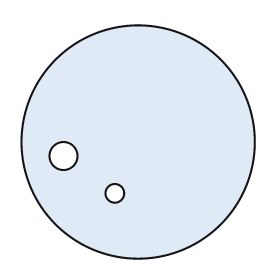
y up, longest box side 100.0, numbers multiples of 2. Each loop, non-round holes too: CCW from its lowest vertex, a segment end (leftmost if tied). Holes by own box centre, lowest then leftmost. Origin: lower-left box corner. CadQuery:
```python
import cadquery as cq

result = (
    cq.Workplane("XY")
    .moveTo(50.0, 50.0)
    .circle(50.0)
    .moveTo(40.0, 28.0)
    .circle(4.0)
    .moveTo(18.0, 44.0)
    .circle(6.0)
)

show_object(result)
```